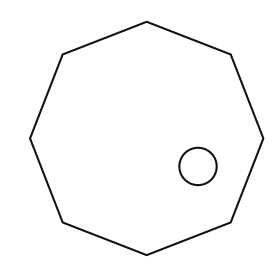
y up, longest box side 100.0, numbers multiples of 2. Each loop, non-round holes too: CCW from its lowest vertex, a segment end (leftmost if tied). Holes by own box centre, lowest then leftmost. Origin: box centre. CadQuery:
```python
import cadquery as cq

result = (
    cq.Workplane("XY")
    .moveTo(0.0, -50.0)
    .lineTo(36.0, -36.0)
    .lineTo(50.0, 0.0)
    .lineTo(36.0, 36.0)
    .lineTo(0.0, 50.0)
    .lineTo(-36.0, 36.0)
    .lineTo(-50.0, 0.0)
    .lineTo(-36.0, -36.0)
    .close()
    .moveTo(22.0, -12.0)
    .circle(8.0)
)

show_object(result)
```